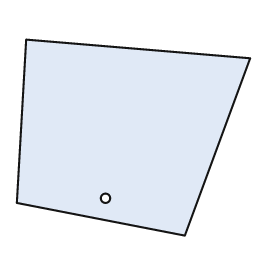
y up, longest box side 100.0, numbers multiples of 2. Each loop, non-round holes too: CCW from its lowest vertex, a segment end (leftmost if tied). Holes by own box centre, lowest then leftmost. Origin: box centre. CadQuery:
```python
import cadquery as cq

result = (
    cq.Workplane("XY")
    .moveTo(22.0, -42.0)
    .lineTo(50.0, 34.0)
    .lineTo(-46.0, 42.0)
    .lineTo(-50.0, -28.0)
    .close()
    .moveTo(-12.0, -26.0)
    .circle(2.0)
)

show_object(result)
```